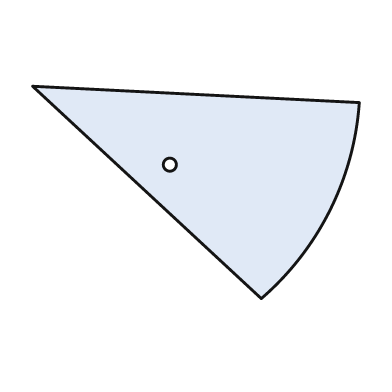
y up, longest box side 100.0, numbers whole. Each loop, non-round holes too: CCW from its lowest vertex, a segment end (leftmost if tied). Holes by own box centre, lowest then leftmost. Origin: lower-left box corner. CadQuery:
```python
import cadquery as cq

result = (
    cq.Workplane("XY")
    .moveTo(70.0, 0.0)
    .threePointArc((91.0, 27.0), (100.0, 60.0))
    .lineTo(0.0, 65.0)
    .close()
    .moveTo(42.0, 41.0)
    .circle(2.0)
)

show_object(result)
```